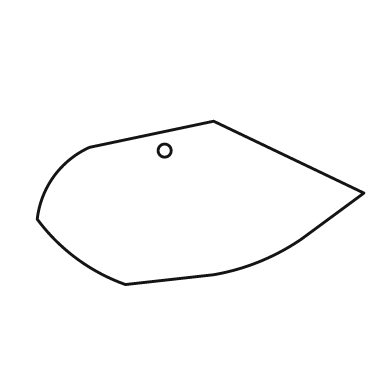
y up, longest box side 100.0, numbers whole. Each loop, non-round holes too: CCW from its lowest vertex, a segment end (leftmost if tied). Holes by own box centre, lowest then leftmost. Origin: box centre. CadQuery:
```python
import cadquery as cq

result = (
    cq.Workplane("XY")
    .moveTo(-23.0, -25.0)
    .lineTo(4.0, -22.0)
    .threePointArc((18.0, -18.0), (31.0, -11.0))
    .lineTo(50.0, 3.0)
    .lineTo(4.0, 25.0)
    .lineTo(-34.0, 17.0)
    .threePointArc((-45.0, 8.0), (-50.0, -5.0))
    .threePointArc((-38.0, -17.0), (-23.0, -25.0))
    .close()
    .moveTo(-11.0, 16.0)
    .circle(2.0)
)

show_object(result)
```